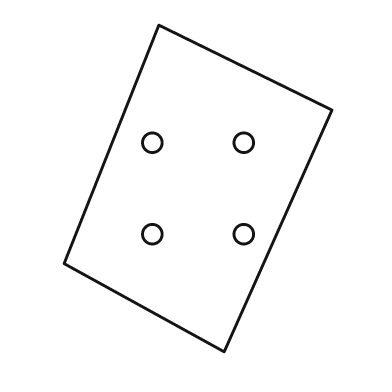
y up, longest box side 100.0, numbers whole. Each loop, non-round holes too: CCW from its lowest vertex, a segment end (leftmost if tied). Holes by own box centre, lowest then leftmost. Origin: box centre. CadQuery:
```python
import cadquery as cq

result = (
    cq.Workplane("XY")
    .moveTo(8.0, -50.0)
    .lineTo(41.0, 24.0)
    .lineTo(-12.0, 50.0)
    .lineTo(-41.0, -23.0)
    .close()
    .moveTo(-14.0, -14.0)
    .circle(3.0)
    .moveTo(14.0, -14.0)
    .circle(3.0)
    .moveTo(-14.0, 14.0)
    .circle(3.0)
    .moveTo(14.0, 14.0)
    .circle(3.0)
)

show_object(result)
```